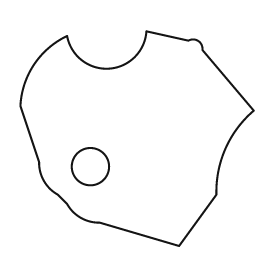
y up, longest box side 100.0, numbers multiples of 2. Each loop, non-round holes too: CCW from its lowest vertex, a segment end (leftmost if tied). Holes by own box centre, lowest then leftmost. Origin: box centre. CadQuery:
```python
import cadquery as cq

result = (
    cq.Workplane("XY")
    .moveTo(18.0, -46.0)
    .lineTo(34.0, -24.0)
    .threePointArc((38.0, -4.0), (50.0, 12.0))
    .lineTo(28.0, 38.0)
    .threePointArc((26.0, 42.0), (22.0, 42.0))
    .lineTo(4.0, 46.0)
    .threePointArc((-12.0, 30.0), (-30.0, 44.0))
    .threePointArc((-44.0, 32.0), (-50.0, 14.0))
    .lineTo(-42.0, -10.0)
    .threePointArc((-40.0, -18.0), (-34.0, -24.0))
    .lineTo(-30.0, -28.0)
    .threePointArc((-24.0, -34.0), (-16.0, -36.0))
    .close()
    .moveTo(-20.0, -12.0)
    .circle(8.0)
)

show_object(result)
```